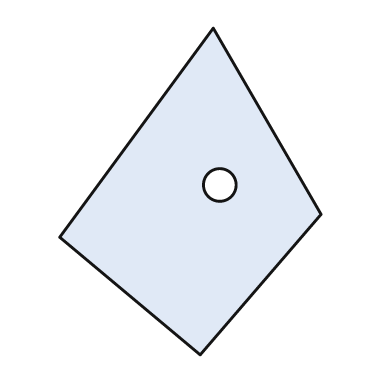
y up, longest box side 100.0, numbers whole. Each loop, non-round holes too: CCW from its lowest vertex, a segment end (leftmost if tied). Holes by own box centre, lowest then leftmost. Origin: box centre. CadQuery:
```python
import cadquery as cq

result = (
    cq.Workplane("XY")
    .moveTo(3.0, -50.0)
    .lineTo(40.0, -7.0)
    .lineTo(7.0, 50.0)
    .lineTo(-40.0, -14.0)
    .close()
    .moveTo(9.0, 2.0)
    .circle(5.0)
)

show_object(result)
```